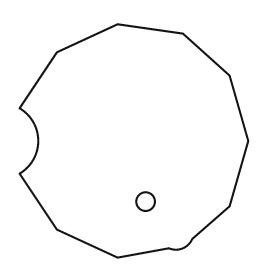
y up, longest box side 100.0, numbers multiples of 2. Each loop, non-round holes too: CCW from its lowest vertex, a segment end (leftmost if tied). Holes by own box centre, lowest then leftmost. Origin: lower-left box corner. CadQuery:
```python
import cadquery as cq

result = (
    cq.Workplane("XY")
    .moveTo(42.0, 0.0)
    .lineTo(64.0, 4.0)
    .threePointArc((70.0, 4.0), (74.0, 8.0))
    .lineTo(90.0, 22.0)
    .lineTo(98.0, 50.0)
    .lineTo(90.0, 78.0)
    .lineTo(70.0, 96.0)
    .lineTo(42.0, 100.0)
    .lineTo(16.0, 88.0)
    .lineTo(0.0, 64.0)
    .threePointArc((8.0, 50.0), (0.0, 36.0))
    .lineTo(16.0, 12.0)
    .close()
    .moveTo(54.0, 24.0)
    .circle(4.0)
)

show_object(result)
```